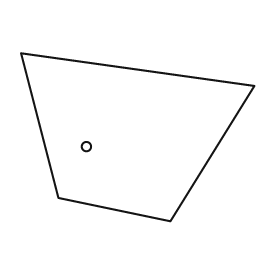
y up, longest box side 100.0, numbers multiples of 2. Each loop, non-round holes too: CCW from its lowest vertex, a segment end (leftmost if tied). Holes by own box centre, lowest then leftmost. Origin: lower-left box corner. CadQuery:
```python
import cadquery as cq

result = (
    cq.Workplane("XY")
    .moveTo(64.0, 0.0)
    .lineTo(100.0, 58.0)
    .lineTo(0.0, 72.0)
    .lineTo(16.0, 10.0)
    .close()
    .moveTo(28.0, 32.0)
    .circle(2.0)
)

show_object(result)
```